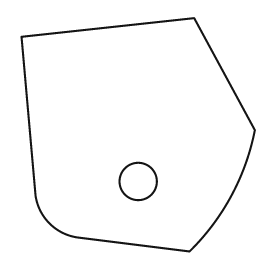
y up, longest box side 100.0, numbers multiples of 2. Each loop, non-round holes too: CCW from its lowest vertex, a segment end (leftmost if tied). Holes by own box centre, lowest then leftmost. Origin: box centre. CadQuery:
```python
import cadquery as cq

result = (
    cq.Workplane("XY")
    .moveTo(22.0, -50.0)
    .threePointArc((40.0, -26.0), (50.0, 2.0))
    .lineTo(24.0, 50.0)
    .lineTo(-50.0, 42.0)
    .lineTo(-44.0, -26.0)
    .threePointArc((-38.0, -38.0), (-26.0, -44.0))
    .close()
    .moveTo(0.0, -20.0)
    .circle(8.0)
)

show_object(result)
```